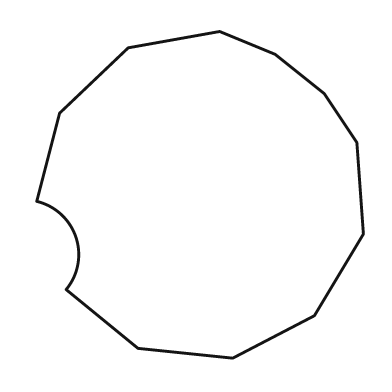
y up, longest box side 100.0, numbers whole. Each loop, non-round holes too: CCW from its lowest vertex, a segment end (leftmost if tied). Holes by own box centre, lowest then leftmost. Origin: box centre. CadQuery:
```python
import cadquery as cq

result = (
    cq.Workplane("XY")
    .moveTo(10.0, -50.0)
    .lineTo(35.0, -37.0)
    .lineTo(50.0, -12.0)
    .lineTo(48.0, 16.0)
    .lineTo(38.0, 31.0)
    .lineTo(23.0, 43.0)
    .lineTo(6.0, 50.0)
    .lineTo(-22.0, 45.0)
    .lineTo(-43.0, 25.0)
    .lineTo(-50.0, -2.0)
    .threePointArc((-38.0, -13.0), (-41.0, -29.0))
    .lineTo(-19.0, -47.0)
    .close()
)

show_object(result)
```